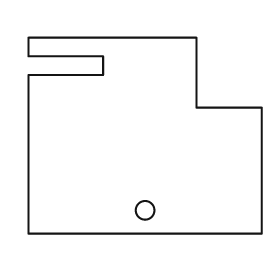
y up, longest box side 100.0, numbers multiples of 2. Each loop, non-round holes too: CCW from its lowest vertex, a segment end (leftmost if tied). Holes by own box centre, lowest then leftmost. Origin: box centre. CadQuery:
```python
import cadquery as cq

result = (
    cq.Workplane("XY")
    .moveTo(-50.0, -42.0)
    .lineTo(50.0, -42.0)
    .lineTo(50.0, 12.0)
    .lineTo(22.0, 12.0)
    .lineTo(22.0, 42.0)
    .lineTo(-50.0, 42.0)
    .lineTo(-50.0, 34.0)
    .lineTo(-18.0, 34.0)
    .lineTo(-18.0, 26.0)
    .lineTo(-50.0, 26.0)
    .close()
    .moveTo(0.0, -32.0)
    .circle(4.0)
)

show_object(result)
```